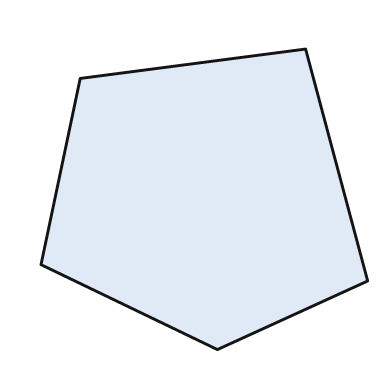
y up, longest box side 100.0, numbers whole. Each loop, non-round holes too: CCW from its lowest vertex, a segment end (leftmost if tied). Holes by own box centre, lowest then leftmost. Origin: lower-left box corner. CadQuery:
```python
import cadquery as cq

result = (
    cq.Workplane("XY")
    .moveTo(54.0, 0.0)
    .lineTo(100.0, 21.0)
    .lineTo(81.0, 92.0)
    .lineTo(12.0, 83.0)
    .lineTo(0.0, 26.0)
    .close()
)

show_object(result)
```